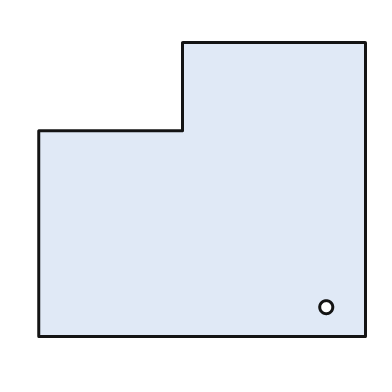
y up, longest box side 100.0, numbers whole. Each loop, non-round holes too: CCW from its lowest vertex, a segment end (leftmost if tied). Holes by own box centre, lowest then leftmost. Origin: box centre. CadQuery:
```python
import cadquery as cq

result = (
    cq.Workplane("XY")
    .moveTo(-50.0, -45.0)
    .lineTo(50.0, -45.0)
    .lineTo(50.0, 45.0)
    .lineTo(-6.0, 45.0)
    .lineTo(-6.0, 18.0)
    .lineTo(-50.0, 18.0)
    .close()
    .moveTo(38.0, -36.0)
    .circle(2.0)
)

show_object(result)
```